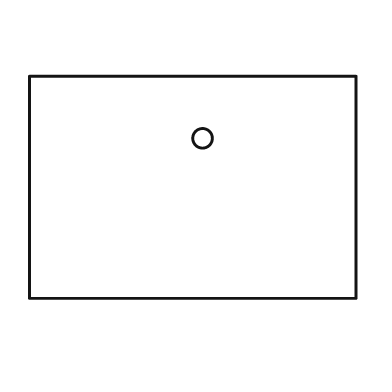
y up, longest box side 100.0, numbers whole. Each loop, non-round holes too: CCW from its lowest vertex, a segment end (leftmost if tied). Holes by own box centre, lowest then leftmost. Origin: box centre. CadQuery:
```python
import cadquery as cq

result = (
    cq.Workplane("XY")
    .moveTo(-50.0, -34.0)
    .lineTo(50.0, -34.0)
    .lineTo(50.0, 34.0)
    .lineTo(-50.0, 34.0)
    .close()
    .moveTo(3.0, 15.0)
    .circle(3.0)
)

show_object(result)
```